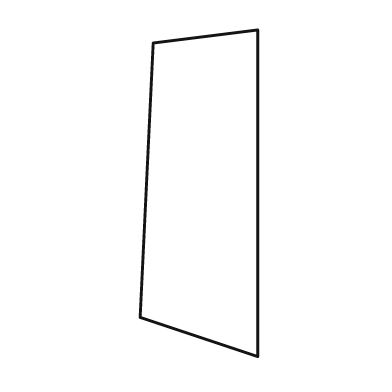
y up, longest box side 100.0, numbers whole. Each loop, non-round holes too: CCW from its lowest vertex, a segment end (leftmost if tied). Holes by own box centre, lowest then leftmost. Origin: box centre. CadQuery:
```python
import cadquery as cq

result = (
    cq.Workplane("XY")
    .moveTo(18.0, -50.0)
    .lineTo(18.0, 50.0)
    .lineTo(-14.0, 46.0)
    .lineTo(-18.0, -38.0)
    .close()
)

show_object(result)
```